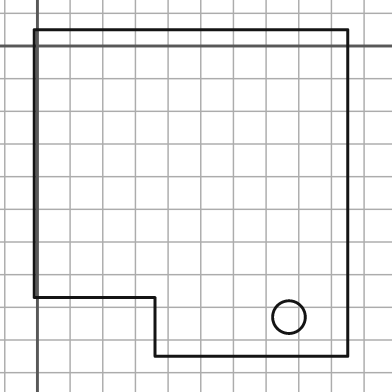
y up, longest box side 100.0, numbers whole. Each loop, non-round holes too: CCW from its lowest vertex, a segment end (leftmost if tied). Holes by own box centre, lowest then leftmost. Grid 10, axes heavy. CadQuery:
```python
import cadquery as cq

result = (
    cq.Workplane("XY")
    .moveTo(36.0, -95.0)
    .lineTo(95.0, -95.0)
    .lineTo(95.0, 5.0)
    .lineTo(-1.0, 5.0)
    .lineTo(-1.0, -77.0)
    .lineTo(36.0, -77.0)
    .close()
    .moveTo(77.0, -83.0)
    .circle(5.0)
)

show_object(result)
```